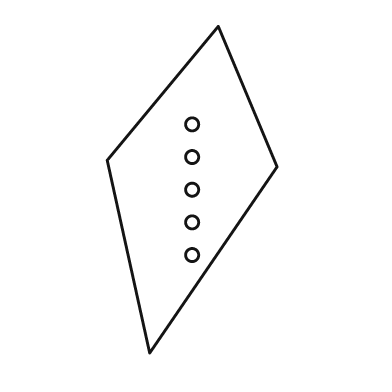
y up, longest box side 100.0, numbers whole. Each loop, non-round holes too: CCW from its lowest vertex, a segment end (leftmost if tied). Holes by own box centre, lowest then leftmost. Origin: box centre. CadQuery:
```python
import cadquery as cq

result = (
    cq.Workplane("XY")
    .moveTo(-13.0, -50.0)
    .lineTo(26.0, 7.0)
    .lineTo(8.0, 50.0)
    .lineTo(-26.0, 9.0)
    .close()
    .moveTo(0.0, -20.0)
    .circle(2.0)
    .moveTo(0.0, -10.0)
    .circle(2.0)
    .moveTo(0.0, 0.0)
    .circle(2.0)
    .moveTo(0.0, 10.0)
    .circle(2.0)
    .moveTo(0.0, 20.0)
    .circle(2.0)
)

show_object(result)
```